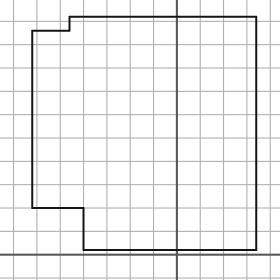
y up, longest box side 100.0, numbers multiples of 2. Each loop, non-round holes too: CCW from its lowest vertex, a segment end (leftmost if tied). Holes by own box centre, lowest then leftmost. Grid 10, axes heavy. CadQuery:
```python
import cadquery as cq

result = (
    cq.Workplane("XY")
    .moveTo(-40.0, 2.0)
    .lineTo(34.0, 2.0)
    .lineTo(34.0, 102.0)
    .lineTo(-46.0, 102.0)
    .lineTo(-46.0, 96.0)
    .lineTo(-62.0, 96.0)
    .lineTo(-62.0, 20.0)
    .lineTo(-40.0, 20.0)
    .close()
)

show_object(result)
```